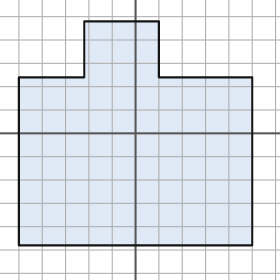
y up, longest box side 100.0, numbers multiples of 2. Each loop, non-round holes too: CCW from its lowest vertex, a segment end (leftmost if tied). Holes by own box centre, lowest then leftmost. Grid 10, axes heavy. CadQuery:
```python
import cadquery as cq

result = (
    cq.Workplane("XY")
    .moveTo(-50.0, -48.0)
    .lineTo(50.0, -48.0)
    .lineTo(50.0, 24.0)
    .lineTo(10.0, 24.0)
    .lineTo(10.0, 48.0)
    .lineTo(-22.0, 48.0)
    .lineTo(-22.0, 24.0)
    .lineTo(-50.0, 24.0)
    .close()
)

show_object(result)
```